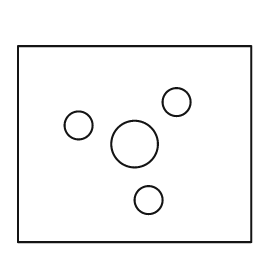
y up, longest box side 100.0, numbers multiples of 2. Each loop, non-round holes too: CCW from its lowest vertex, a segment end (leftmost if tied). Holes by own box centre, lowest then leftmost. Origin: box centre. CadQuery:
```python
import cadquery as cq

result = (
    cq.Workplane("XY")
    .moveTo(-50.0, -42.0)
    .lineTo(50.0, -42.0)
    .lineTo(50.0, 42.0)
    .lineTo(-50.0, 42.0)
    .close()
    .moveTo(6.0, -24.0)
    .circle(6.0)
    .moveTo(0.0, 0.0)
    .circle(10.0)
    .moveTo(-24.0, 8.0)
    .circle(6.0)
    .moveTo(18.0, 18.0)
    .circle(6.0)
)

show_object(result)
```